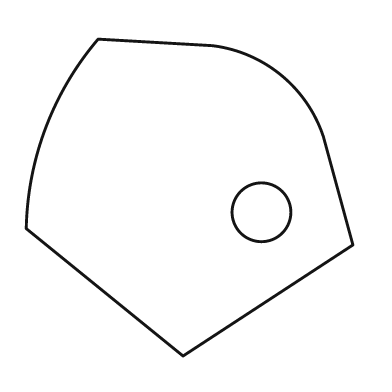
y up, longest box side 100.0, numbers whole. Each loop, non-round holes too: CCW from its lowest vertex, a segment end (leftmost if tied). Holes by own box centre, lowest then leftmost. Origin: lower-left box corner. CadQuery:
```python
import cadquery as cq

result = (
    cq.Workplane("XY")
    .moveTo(48.0, 0.0)
    .lineTo(100.0, 34.0)
    .lineTo(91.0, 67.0)
    .threePointArc((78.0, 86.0), (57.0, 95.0))
    .lineTo(22.0, 97.0)
    .threePointArc((6.0, 70.0), (0.0, 39.0))
    .close()
    .moveTo(72.0, 44.0)
    .circle(9.0)
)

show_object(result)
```